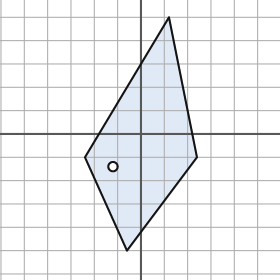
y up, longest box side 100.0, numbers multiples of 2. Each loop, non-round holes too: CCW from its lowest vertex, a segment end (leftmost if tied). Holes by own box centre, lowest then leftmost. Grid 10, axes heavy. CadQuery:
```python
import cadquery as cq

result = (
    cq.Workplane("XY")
    .moveTo(-6.0, -50.0)
    .lineTo(24.0, -10.0)
    .lineTo(12.0, 50.0)
    .lineTo(-24.0, -10.0)
    .close()
    .moveTo(-12.0, -14.0)
    .circle(2.0)
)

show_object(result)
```